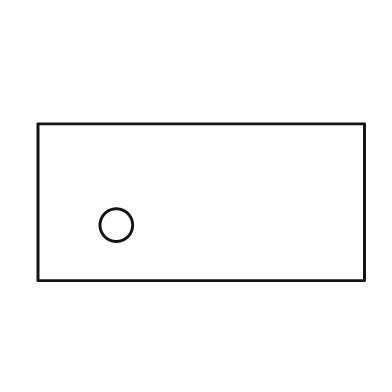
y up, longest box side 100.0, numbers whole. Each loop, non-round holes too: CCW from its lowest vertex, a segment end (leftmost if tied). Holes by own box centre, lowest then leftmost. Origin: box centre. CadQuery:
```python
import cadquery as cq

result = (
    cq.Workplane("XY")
    .moveTo(-50.0, -24.0)
    .lineTo(50.0, -24.0)
    .lineTo(50.0, 24.0)
    .lineTo(-50.0, 24.0)
    .close()
    .moveTo(-26.0, -7.0)
    .circle(5.0)
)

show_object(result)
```